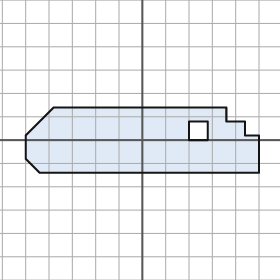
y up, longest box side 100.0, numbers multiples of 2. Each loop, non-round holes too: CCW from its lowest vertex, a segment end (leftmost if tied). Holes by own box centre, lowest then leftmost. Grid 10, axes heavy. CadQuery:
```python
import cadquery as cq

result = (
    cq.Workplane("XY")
    .moveTo(-44.0, -14.0)
    .lineTo(50.0, -14.0)
    .lineTo(50.0, 2.0)
    .lineTo(44.0, 2.0)
    .lineTo(44.0, 8.0)
    .lineTo(36.0, 8.0)
    .lineTo(36.0, 14.0)
    .lineTo(-38.0, 14.0)
    .lineTo(-50.0, 2.0)
    .lineTo(-50.0, -8.0)
    .close()
    .moveTo(20.0, 0.0)
    .lineTo(28.0, 0.0)
    .lineTo(28.0, 8.0)
    .lineTo(20.0, 8.0)
    .close()
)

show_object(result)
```